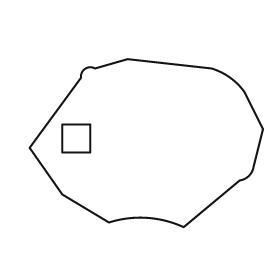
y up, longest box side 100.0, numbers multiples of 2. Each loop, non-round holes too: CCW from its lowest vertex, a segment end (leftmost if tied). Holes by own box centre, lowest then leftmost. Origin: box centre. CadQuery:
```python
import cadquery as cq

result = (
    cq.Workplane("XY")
    .moveTo(16.0, -36.0)
    .lineTo(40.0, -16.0)
    .threePointArc((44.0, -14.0), (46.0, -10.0))
    .lineTo(50.0, 6.0)
    .lineTo(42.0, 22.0)
    .threePointArc((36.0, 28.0), (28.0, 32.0))
    .lineTo(-8.0, 36.0)
    .lineTo(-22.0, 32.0)
    .threePointArc((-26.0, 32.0), (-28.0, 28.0))
    .lineTo(-50.0, -2.0)
    .lineTo(-36.0, -22.0)
    .lineTo(-16.0, -34.0)
    .threePointArc((0.0, -32.0), (16.0, -36.0))
    .close()
    .moveTo(-36.0, -4.0)
    .lineTo(-24.0, -4.0)
    .lineTo(-24.0, 8.0)
    .lineTo(-36.0, 8.0)
    .close()
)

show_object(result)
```